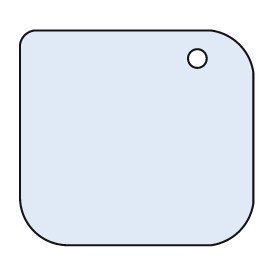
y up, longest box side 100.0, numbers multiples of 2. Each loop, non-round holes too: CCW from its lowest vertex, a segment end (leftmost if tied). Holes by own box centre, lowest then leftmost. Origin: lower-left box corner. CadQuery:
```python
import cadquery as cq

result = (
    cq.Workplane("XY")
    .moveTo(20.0, 0.0)
    .lineTo(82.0, 0.0)
    .threePointArc((94.0, 6.0), (100.0, 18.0))
    .lineTo(100.0, 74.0)
    .threePointArc((94.0, 86.0), (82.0, 92.0))
    .lineTo(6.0, 92.0)
    .threePointArc((2.0, 90.0), (0.0, 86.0))
    .lineTo(0.0, 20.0)
    .threePointArc((6.0, 6.0), (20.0, 0.0))
    .close()
    .moveTo(76.0, 80.0)
    .circle(4.0)
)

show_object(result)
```